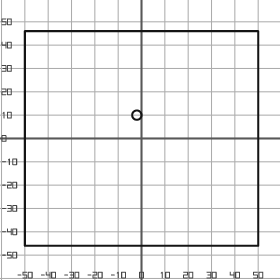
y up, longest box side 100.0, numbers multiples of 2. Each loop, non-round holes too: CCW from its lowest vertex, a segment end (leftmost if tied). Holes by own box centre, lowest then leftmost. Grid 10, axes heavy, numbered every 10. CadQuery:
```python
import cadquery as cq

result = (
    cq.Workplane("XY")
    .moveTo(-50.0, -46.0)
    .lineTo(50.0, -46.0)
    .lineTo(50.0, 46.0)
    .lineTo(-50.0, 46.0)
    .close()
    .moveTo(-2.0, 10.0)
    .circle(2.0)
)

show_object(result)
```